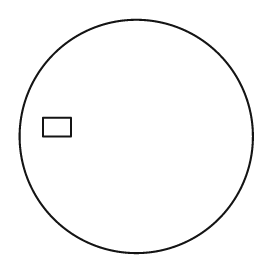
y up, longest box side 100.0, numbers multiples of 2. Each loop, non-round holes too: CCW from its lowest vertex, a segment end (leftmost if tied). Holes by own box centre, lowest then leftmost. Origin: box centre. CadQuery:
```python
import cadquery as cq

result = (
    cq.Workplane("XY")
    .moveTo(0.0, 0.0)
    .circle(50.0)
    .moveTo(-40.0, 0.0)
    .lineTo(-28.0, 0.0)
    .lineTo(-28.0, 8.0)
    .lineTo(-40.0, 8.0)
    .close()
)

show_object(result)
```